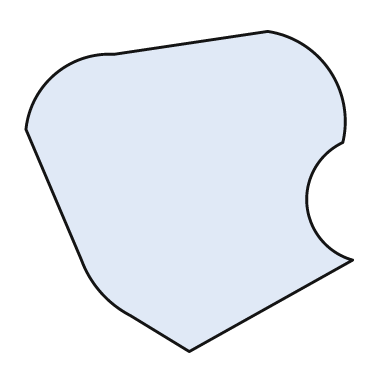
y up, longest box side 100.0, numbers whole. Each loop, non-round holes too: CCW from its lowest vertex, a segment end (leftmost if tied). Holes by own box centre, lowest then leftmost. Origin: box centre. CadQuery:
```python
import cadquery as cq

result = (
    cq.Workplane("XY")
    .moveTo(0.0, -49.0)
    .lineTo(50.0, -21.0)
    .threePointArc((36.0, -4.0), (47.0, 15.0))
    .threePointArc((43.0, 37.0), (24.0, 49.0))
    .lineTo(-23.0, 42.0)
    .threePointArc((-41.0, 36.0), (-50.0, 19.0))
    .lineTo(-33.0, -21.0)
    .threePointArc((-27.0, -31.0), (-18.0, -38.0))
    .close()
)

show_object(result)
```